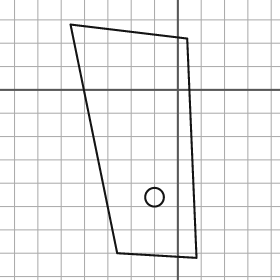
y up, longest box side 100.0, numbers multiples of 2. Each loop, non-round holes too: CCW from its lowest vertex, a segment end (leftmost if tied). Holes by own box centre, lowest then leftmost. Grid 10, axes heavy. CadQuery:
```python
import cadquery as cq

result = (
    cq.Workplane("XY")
    .moveTo(8.0, -72.0)
    .lineTo(4.0, 22.0)
    .lineTo(-46.0, 28.0)
    .lineTo(-26.0, -70.0)
    .close()
    .moveTo(-10.0, -46.0)
    .circle(4.0)
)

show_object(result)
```